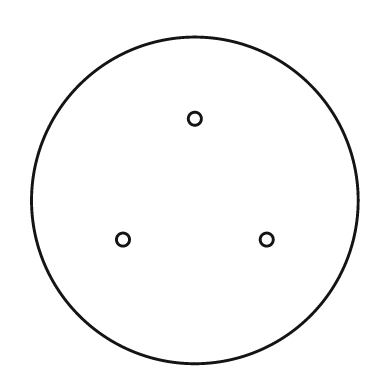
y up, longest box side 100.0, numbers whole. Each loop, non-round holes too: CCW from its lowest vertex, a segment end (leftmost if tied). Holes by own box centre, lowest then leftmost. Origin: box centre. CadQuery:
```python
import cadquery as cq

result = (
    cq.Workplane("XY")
    .moveTo(0.0, 0.0)
    .circle(50.0)
    .moveTo(-22.0, -12.0)
    .circle(2.0)
    .moveTo(22.0, -12.0)
    .circle(2.0)
    .moveTo(0.0, 25.0)
    .circle(2.0)
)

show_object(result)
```